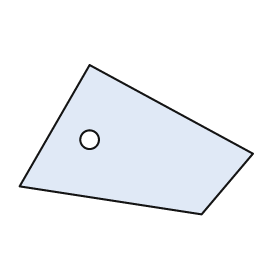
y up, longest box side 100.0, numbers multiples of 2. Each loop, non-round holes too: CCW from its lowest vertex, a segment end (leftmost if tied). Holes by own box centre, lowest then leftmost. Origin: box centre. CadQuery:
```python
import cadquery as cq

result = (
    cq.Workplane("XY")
    .moveTo(28.0, -32.0)
    .lineTo(50.0, -6.0)
    .lineTo(-20.0, 32.0)
    .lineTo(-50.0, -20.0)
    .close()
    .moveTo(-20.0, 0.0)
    .circle(4.0)
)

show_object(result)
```